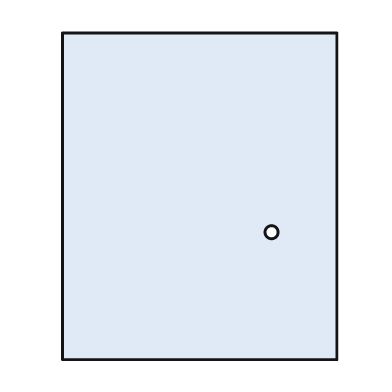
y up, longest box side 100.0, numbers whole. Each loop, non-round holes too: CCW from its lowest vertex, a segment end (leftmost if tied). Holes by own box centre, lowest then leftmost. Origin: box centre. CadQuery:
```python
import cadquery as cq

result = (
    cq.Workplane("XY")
    .moveTo(-42.0, -50.0)
    .lineTo(42.0, -50.0)
    .lineTo(42.0, 50.0)
    .lineTo(-42.0, 50.0)
    .close()
    .moveTo(22.0, -11.0)
    .circle(2.0)
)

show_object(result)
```